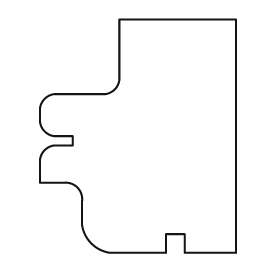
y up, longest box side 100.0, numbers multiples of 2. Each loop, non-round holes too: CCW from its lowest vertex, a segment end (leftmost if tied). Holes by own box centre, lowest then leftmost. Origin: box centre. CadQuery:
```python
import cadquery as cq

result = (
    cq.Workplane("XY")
    .moveTo(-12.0, -50.0)
    .lineTo(12.0, -50.0)
    .lineTo(12.0, -42.0)
    .lineTo(20.0, -42.0)
    .lineTo(20.0, -50.0)
    .lineTo(42.0, -50.0)
    .lineTo(42.0, 50.0)
    .lineTo(-8.0, 50.0)
    .lineTo(-8.0, 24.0)
    .threePointArc((-10.0, 20.0), (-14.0, 18.0))
    .lineTo(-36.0, 18.0)
    .threePointArc((-40.0, 16.0), (-42.0, 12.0))
    .lineTo(-42.0, 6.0)
    .threePointArc((-40.0, 2.0), (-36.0, 0.0))
    .lineTo(-28.0, 0.0)
    .lineTo(-28.0, -4.0)
    .lineTo(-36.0, -4.0)
    .threePointArc((-40.0, -6.0), (-42.0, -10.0))
    .lineTo(-42.0, -20.0)
    .lineTo(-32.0, -20.0)
    .threePointArc((-26.0, -22.0), (-24.0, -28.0))
    .lineTo(-24.0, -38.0)
    .threePointArc((-20.0, -46.0), (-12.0, -50.0))
    .close()
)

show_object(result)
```